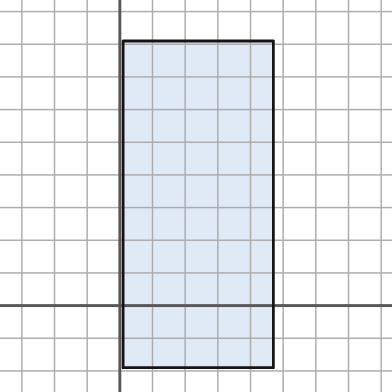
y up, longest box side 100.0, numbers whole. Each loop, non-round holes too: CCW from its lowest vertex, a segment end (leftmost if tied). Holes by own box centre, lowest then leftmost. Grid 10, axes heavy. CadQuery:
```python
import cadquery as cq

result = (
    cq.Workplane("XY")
    .moveTo(1.0, -19.0)
    .lineTo(47.0, -19.0)
    .lineTo(47.0, 81.0)
    .lineTo(1.0, 81.0)
    .close()
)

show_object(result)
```